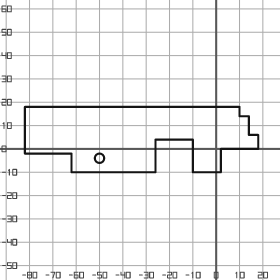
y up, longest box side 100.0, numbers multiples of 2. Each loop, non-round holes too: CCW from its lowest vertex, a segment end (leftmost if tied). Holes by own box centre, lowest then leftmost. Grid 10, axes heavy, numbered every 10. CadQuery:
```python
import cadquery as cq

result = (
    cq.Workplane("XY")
    .moveTo(-62.0, -10.0)
    .lineTo(-26.0, -10.0)
    .lineTo(-26.0, 4.0)
    .lineTo(-10.0, 4.0)
    .lineTo(-10.0, -10.0)
    .lineTo(2.0, -10.0)
    .lineTo(2.0, 0.0)
    .lineTo(18.0, 0.0)
    .lineTo(18.0, 6.0)
    .lineTo(14.0, 6.0)
    .lineTo(14.0, 14.0)
    .lineTo(10.0, 14.0)
    .lineTo(10.0, 18.0)
    .lineTo(-82.0, 18.0)
    .lineTo(-82.0, -2.0)
    .lineTo(-62.0, -2.0)
    .close()
    .moveTo(-50.0, -4.0)
    .circle(2.0)
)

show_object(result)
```